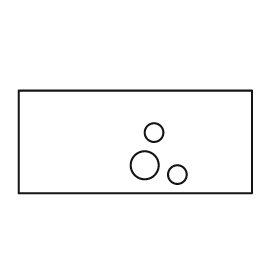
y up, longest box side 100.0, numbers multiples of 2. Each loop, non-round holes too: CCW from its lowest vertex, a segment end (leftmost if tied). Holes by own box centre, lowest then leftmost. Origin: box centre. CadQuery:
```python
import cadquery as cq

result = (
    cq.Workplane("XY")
    .moveTo(-50.0, -22.0)
    .lineTo(50.0, -22.0)
    .lineTo(50.0, 22.0)
    .lineTo(-50.0, 22.0)
    .close()
    .moveTo(18.0, -14.0)
    .circle(4.0)
    .moveTo(4.0, -10.0)
    .circle(6.0)
    .moveTo(8.0, 4.0)
    .circle(4.0)
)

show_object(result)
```